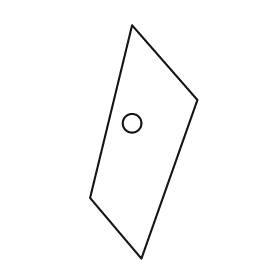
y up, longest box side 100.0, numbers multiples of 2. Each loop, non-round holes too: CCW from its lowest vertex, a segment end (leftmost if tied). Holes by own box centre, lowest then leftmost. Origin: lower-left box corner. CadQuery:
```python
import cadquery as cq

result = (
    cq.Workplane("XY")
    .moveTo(22.0, 0.0)
    .lineTo(46.0, 68.0)
    .lineTo(18.0, 100.0)
    .lineTo(0.0, 26.0)
    .close()
    .moveTo(18.0, 58.0)
    .circle(4.0)
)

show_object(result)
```